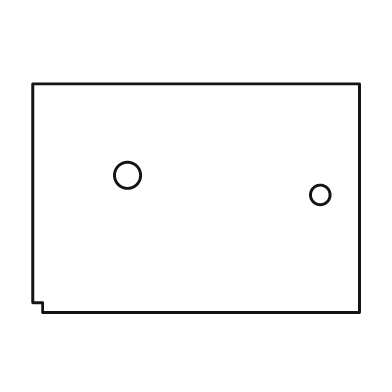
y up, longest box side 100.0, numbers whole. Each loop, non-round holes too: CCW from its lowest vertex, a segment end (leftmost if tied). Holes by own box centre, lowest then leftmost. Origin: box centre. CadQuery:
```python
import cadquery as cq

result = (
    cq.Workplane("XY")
    .moveTo(-47.0, -35.0)
    .lineTo(50.0, -35.0)
    .lineTo(50.0, 35.0)
    .lineTo(-50.0, 35.0)
    .lineTo(-50.0, -32.0)
    .lineTo(-47.0, -32.0)
    .close()
    .moveTo(38.0, 1.0)
    .circle(3.0)
    .moveTo(-21.0, 7.0)
    .circle(4.0)
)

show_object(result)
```